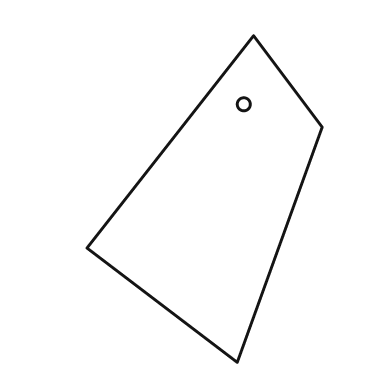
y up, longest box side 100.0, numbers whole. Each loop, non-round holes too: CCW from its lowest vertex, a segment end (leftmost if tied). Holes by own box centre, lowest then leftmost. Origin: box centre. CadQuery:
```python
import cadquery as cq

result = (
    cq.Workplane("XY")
    .moveTo(10.0, -50.0)
    .lineTo(36.0, 22.0)
    .lineTo(15.0, 50.0)
    .lineTo(-36.0, -15.0)
    .close()
    .moveTo(12.0, 29.0)
    .circle(2.0)
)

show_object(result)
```